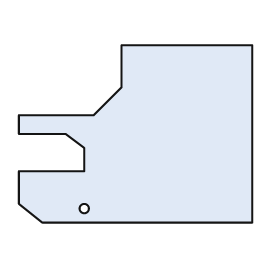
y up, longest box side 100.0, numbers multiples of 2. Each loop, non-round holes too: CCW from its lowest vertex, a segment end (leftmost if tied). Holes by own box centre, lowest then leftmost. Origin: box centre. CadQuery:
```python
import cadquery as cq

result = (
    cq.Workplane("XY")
    .moveTo(-40.0, -38.0)
    .lineTo(50.0, -38.0)
    .lineTo(50.0, 38.0)
    .lineTo(-6.0, 38.0)
    .lineTo(-6.0, 20.0)
    .lineTo(-18.0, 8.0)
    .lineTo(-50.0, 8.0)
    .lineTo(-50.0, 0.0)
    .lineTo(-30.0, 0.0)
    .lineTo(-22.0, -6.0)
    .lineTo(-22.0, -16.0)
    .lineTo(-50.0, -16.0)
    .lineTo(-50.0, -30.0)
    .close()
    .moveTo(-22.0, -32.0)
    .circle(2.0)
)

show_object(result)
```